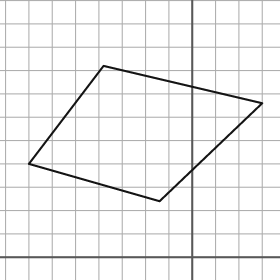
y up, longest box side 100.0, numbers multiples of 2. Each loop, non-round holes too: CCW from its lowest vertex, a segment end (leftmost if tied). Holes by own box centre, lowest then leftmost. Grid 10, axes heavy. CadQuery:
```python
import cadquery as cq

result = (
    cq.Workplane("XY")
    .moveTo(-14.0, 24.0)
    .lineTo(30.0, 66.0)
    .lineTo(-38.0, 82.0)
    .lineTo(-70.0, 40.0)
    .close()
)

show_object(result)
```